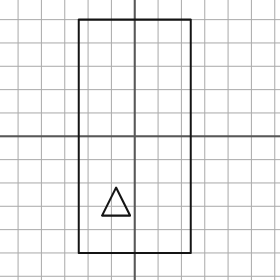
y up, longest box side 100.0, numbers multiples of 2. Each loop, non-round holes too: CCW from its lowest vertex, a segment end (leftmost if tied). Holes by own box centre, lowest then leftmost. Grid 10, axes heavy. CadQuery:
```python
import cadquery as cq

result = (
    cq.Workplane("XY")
    .moveTo(-24.0, -50.0)
    .lineTo(24.0, -50.0)
    .lineTo(24.0, 50.0)
    .lineTo(-24.0, 50.0)
    .close()
    .moveTo(-14.0, -34.0)
    .lineTo(-2.0, -34.0)
    .lineTo(-8.0, -22.0)
    .close()
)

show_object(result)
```